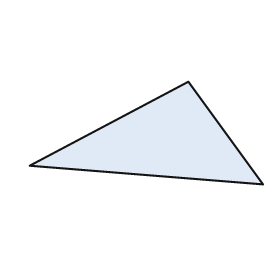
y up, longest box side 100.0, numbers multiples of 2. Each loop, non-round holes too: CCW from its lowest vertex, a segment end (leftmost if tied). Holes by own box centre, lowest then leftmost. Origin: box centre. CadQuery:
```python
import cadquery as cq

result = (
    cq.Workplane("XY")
    .moveTo(50.0, -22.0)
    .lineTo(18.0, 22.0)
    .lineTo(-50.0, -14.0)
    .close()
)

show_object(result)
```